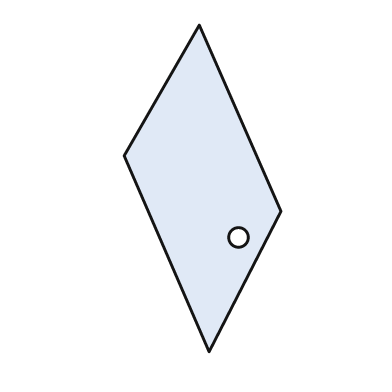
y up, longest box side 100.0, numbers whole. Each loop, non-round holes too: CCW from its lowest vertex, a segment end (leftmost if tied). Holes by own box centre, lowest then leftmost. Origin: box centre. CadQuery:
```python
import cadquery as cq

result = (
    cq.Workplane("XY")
    .moveTo(2.0, -50.0)
    .lineTo(24.0, -7.0)
    .lineTo(-1.0, 50.0)
    .lineTo(-24.0, 10.0)
    .close()
    .moveTo(11.0, -15.0)
    .circle(3.0)
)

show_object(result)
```